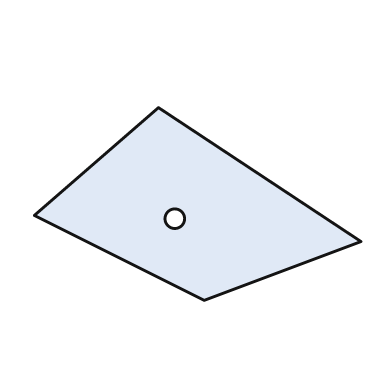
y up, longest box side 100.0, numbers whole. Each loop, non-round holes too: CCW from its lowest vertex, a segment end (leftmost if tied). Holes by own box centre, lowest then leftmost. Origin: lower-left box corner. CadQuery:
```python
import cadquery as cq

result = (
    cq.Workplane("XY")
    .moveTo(52.0, 0.0)
    .lineTo(100.0, 18.0)
    .lineTo(38.0, 59.0)
    .lineTo(0.0, 26.0)
    .close()
    .moveTo(43.0, 25.0)
    .circle(3.0)
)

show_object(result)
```